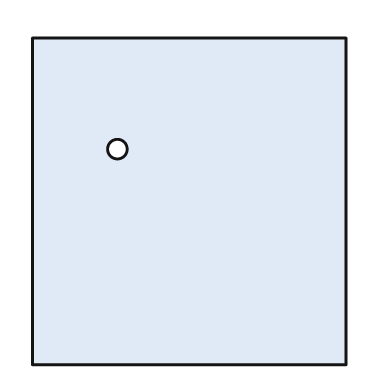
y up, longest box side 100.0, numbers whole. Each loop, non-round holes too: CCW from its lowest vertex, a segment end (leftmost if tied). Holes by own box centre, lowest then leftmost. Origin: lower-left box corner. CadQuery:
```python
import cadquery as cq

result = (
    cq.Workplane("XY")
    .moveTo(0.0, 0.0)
    .lineTo(96.0, 0.0)
    .lineTo(96.0, 100.0)
    .lineTo(0.0, 100.0)
    .close()
    .moveTo(26.0, 66.0)
    .circle(3.0)
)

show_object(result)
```